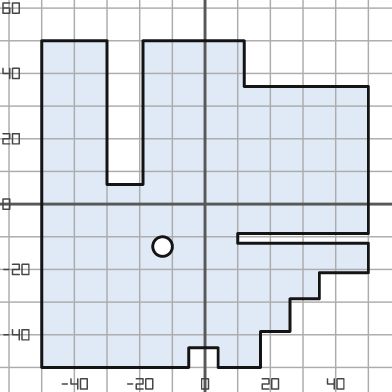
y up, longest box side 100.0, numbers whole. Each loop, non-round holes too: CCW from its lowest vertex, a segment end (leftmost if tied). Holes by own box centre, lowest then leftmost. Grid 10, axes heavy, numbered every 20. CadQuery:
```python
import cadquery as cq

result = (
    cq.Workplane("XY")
    .moveTo(-50.0, -50.0)
    .lineTo(-5.0, -50.0)
    .lineTo(-5.0, -44.0)
    .lineTo(4.0, -44.0)
    .lineTo(4.0, -50.0)
    .lineTo(17.0, -50.0)
    .lineTo(17.0, -39.0)
    .lineTo(26.0, -39.0)
    .lineTo(26.0, -29.0)
    .lineTo(35.0, -29.0)
    .lineTo(35.0, -21.0)
    .lineTo(50.0, -21.0)
    .lineTo(50.0, -12.0)
    .lineTo(10.0, -12.0)
    .lineTo(10.0, -9.0)
    .lineTo(50.0, -9.0)
    .lineTo(50.0, 36.0)
    .lineTo(12.0, 36.0)
    .lineTo(12.0, 50.0)
    .lineTo(-19.0, 50.0)
    .lineTo(-19.0, 6.0)
    .lineTo(-30.0, 6.0)
    .lineTo(-30.0, 50.0)
    .lineTo(-50.0, 50.0)
    .close()
    .moveTo(-13.0, -13.0)
    .circle(3.0)
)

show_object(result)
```